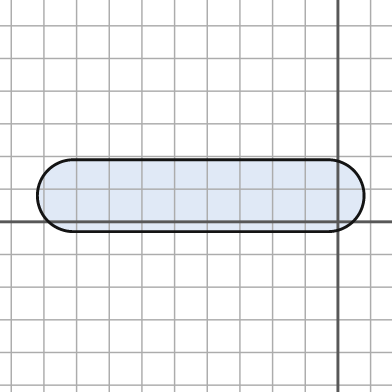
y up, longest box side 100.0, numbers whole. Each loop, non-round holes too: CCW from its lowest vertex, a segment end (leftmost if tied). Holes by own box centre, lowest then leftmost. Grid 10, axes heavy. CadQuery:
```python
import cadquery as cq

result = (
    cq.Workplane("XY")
    .moveTo(-81.0, -3.0)
    .lineTo(-3.0, -3.0)
    .threePointArc((8.0, 8.0), (-3.0, 19.0))
    .lineTo(-81.0, 19.0)
    .threePointArc((-92.0, 8.0), (-81.0, -3.0))
    .close()
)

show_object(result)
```